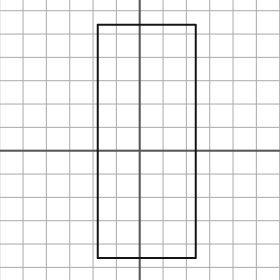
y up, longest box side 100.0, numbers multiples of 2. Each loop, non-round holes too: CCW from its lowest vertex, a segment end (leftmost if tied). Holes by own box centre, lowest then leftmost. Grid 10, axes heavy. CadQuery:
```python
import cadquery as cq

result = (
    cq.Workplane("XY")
    .moveTo(-18.0, -46.0)
    .lineTo(24.0, -46.0)
    .lineTo(24.0, 54.0)
    .lineTo(-18.0, 54.0)
    .close()
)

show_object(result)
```